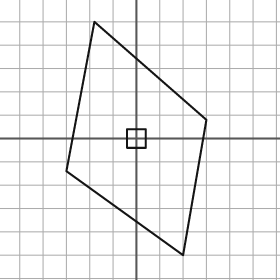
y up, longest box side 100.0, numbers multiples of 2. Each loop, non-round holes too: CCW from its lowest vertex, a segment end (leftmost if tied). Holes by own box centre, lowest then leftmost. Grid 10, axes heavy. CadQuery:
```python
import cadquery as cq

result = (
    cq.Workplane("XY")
    .moveTo(20.0, -50.0)
    .lineTo(30.0, 8.0)
    .lineTo(-18.0, 50.0)
    .lineTo(-30.0, -14.0)
    .close()
    .moveTo(-4.0, -4.0)
    .lineTo(4.0, -4.0)
    .lineTo(4.0, 4.0)
    .lineTo(-4.0, 4.0)
    .close()
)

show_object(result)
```